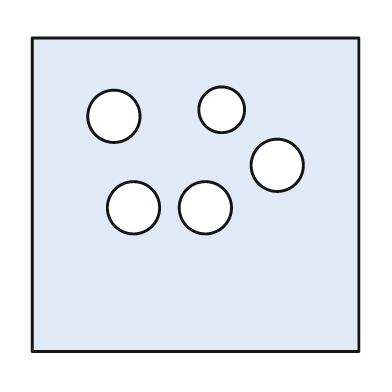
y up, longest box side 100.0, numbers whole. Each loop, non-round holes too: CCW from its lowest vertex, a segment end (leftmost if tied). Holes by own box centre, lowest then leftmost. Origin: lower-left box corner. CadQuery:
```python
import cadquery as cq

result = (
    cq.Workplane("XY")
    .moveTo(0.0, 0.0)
    .lineTo(100.0, 0.0)
    .lineTo(100.0, 96.0)
    .lineTo(0.0, 96.0)
    .close()
    .moveTo(31.0, 44.0)
    .circle(8.0)
    .moveTo(53.0, 44.0)
    .circle(8.0)
    .moveTo(75.0, 57.0)
    .circle(8.0)
    .moveTo(25.0, 72.0)
    .circle(8.0)
    .moveTo(58.0, 74.0)
    .circle(7.0)
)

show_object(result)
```